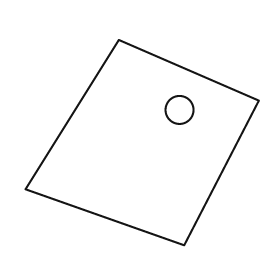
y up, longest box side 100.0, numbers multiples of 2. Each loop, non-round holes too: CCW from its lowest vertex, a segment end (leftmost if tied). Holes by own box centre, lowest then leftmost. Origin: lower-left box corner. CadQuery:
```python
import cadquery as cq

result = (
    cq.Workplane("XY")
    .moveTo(68.0, 0.0)
    .lineTo(100.0, 62.0)
    .lineTo(40.0, 88.0)
    .lineTo(0.0, 24.0)
    .close()
    .moveTo(66.0, 58.0)
    .circle(6.0)
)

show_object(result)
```